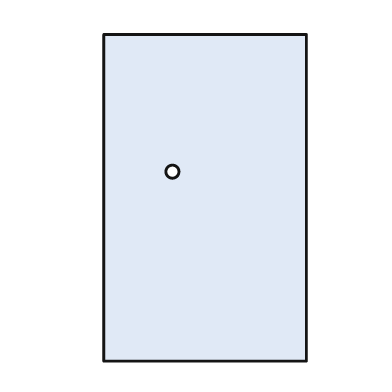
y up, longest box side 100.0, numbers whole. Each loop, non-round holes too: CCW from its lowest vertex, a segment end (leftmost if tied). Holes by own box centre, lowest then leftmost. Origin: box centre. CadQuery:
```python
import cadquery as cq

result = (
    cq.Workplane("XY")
    .moveTo(-31.0, -50.0)
    .lineTo(31.0, -50.0)
    .lineTo(31.0, 50.0)
    .lineTo(-31.0, 50.0)
    .close()
    .moveTo(-10.0, 8.0)
    .circle(2.0)
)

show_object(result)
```